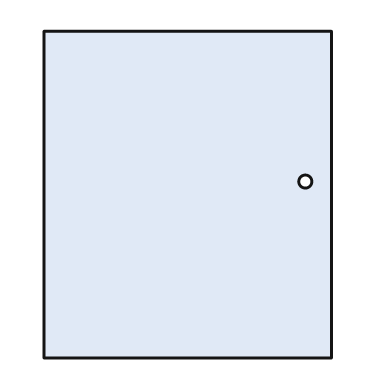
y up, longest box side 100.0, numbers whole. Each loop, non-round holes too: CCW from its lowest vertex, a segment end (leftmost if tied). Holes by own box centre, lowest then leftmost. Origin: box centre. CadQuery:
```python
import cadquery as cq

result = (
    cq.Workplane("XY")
    .moveTo(-44.0, -50.0)
    .lineTo(44.0, -50.0)
    .lineTo(44.0, 50.0)
    .lineTo(-44.0, 50.0)
    .close()
    .moveTo(36.0, 4.0)
    .circle(2.0)
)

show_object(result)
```